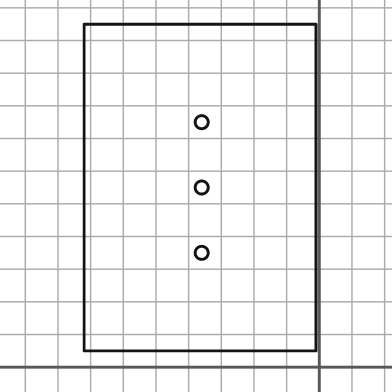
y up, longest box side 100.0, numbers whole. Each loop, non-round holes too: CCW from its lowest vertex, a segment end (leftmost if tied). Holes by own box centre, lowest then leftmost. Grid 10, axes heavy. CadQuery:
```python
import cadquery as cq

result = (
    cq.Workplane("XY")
    .moveTo(-72.0, 5.0)
    .lineTo(-1.0, 5.0)
    .lineTo(-1.0, 105.0)
    .lineTo(-72.0, 105.0)
    .close()
    .moveTo(-36.0, 35.0)
    .circle(2.0)
    .moveTo(-36.0, 55.0)
    .circle(2.0)
    .moveTo(-36.0, 75.0)
    .circle(2.0)
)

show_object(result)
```